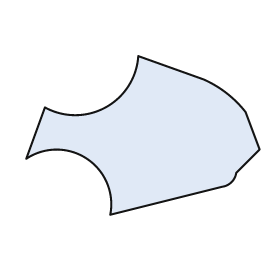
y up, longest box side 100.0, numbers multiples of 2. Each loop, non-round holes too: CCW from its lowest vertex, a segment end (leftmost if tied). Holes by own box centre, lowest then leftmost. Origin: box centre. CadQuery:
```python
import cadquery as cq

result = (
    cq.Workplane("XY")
    .moveTo(-14.0, -34.0)
    .lineTo(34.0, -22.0)
    .threePointArc((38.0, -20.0), (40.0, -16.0))
    .lineTo(50.0, -6.0)
    .lineTo(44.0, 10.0)
    .threePointArc((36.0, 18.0), (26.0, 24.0))
    .lineTo(-2.0, 34.0)
    .threePointArc((-16.0, 12.0), (-42.0, 12.0))
    .lineTo(-50.0, -10.0)
    .threePointArc((-24.0, -10.0), (-14.0, -34.0))
    .close()
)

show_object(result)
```